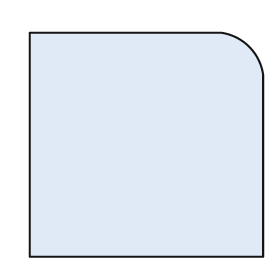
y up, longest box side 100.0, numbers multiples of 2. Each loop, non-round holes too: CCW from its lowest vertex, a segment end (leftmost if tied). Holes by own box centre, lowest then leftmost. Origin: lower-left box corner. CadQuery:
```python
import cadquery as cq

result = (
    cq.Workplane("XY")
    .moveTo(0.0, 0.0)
    .lineTo(100.0, 0.0)
    .lineTo(100.0, 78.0)
    .threePointArc((94.0, 90.0), (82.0, 96.0))
    .lineTo(0.0, 96.0)
    .close()
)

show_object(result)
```